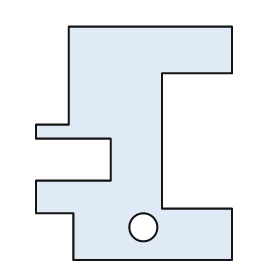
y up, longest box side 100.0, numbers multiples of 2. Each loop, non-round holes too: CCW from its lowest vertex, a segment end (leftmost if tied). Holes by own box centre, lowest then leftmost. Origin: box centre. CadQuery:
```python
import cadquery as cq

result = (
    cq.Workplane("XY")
    .moveTo(-26.0, -50.0)
    .lineTo(42.0, -50.0)
    .lineTo(42.0, -28.0)
    .lineTo(12.0, -28.0)
    .lineTo(12.0, 30.0)
    .lineTo(42.0, 30.0)
    .lineTo(42.0, 50.0)
    .lineTo(-28.0, 50.0)
    .lineTo(-28.0, 8.0)
    .lineTo(-42.0, 8.0)
    .lineTo(-42.0, 2.0)
    .lineTo(-10.0, 2.0)
    .lineTo(-10.0, -16.0)
    .lineTo(-42.0, -16.0)
    .lineTo(-42.0, -30.0)
    .lineTo(-26.0, -30.0)
    .close()
    .moveTo(4.0, -36.0)
    .circle(6.0)
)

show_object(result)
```